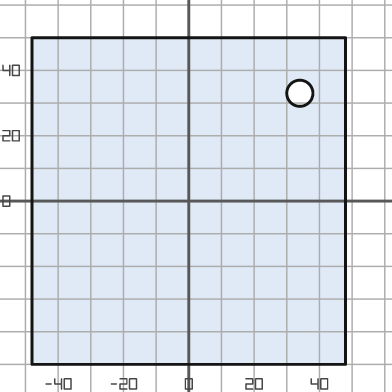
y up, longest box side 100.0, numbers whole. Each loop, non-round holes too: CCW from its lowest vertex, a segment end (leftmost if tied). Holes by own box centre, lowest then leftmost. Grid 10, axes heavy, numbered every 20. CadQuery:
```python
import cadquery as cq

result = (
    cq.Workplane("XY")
    .moveTo(-48.0, -50.0)
    .lineTo(48.0, -50.0)
    .lineTo(48.0, 50.0)
    .lineTo(-48.0, 50.0)
    .close()
    .moveTo(34.0, 33.0)
    .circle(4.0)
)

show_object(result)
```